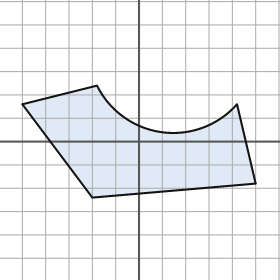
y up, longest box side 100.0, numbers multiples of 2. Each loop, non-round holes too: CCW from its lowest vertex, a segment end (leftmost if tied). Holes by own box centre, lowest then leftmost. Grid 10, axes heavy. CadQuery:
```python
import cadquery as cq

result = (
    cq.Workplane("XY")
    .moveTo(-20.0, -24.0)
    .lineTo(50.0, -18.0)
    .lineTo(42.0, 16.0)
    .threePointArc((10.0, 4.0), (-18.0, 24.0))
    .lineTo(-50.0, 16.0)
    .close()
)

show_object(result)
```